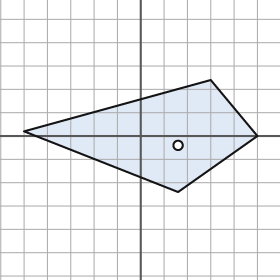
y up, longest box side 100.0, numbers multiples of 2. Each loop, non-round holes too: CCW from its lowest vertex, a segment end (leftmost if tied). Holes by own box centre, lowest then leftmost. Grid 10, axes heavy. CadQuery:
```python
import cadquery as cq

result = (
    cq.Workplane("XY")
    .moveTo(16.0, -24.0)
    .lineTo(50.0, 0.0)
    .lineTo(30.0, 24.0)
    .lineTo(-50.0, 2.0)
    .close()
    .moveTo(16.0, -4.0)
    .circle(2.0)
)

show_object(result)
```